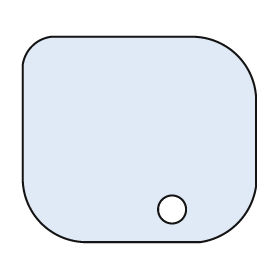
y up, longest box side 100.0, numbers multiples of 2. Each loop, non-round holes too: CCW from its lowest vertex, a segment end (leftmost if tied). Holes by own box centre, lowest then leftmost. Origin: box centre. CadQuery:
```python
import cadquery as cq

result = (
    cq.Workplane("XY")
    .moveTo(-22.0, -44.0)
    .lineTo(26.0, -44.0)
    .threePointArc((42.0, -36.0), (50.0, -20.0))
    .lineTo(50.0, 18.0)
    .threePointArc((42.0, 36.0), (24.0, 44.0))
    .lineTo(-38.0, 44.0)
    .threePointArc((-46.0, 40.0), (-50.0, 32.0))
    .lineTo(-50.0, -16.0)
    .threePointArc((-42.0, -36.0), (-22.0, -44.0))
    .close()
    .moveTo(14.0, -30.0)
    .circle(6.0)
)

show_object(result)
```